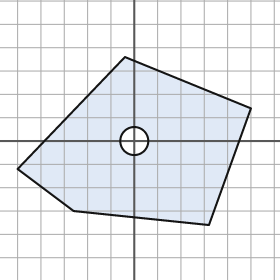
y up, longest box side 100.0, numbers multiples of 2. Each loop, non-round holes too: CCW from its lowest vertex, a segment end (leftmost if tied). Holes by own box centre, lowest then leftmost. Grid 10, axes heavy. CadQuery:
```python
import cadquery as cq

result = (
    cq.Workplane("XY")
    .moveTo(32.0, -36.0)
    .lineTo(50.0, 14.0)
    .lineTo(-4.0, 36.0)
    .lineTo(-50.0, -12.0)
    .lineTo(-26.0, -30.0)
    .close()
    .moveTo(0.0, 0.0)
    .circle(6.0)
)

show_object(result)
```